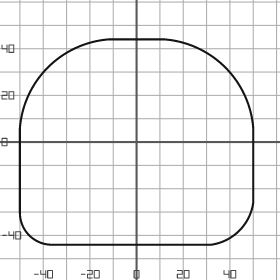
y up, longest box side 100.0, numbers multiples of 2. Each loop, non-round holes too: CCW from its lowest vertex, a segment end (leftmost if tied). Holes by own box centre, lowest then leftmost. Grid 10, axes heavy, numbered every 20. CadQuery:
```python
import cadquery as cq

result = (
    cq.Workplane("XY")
    .moveTo(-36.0, -44.0)
    .lineTo(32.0, -44.0)
    .threePointArc((44.0, -38.0), (50.0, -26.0))
    .lineTo(50.0, 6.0)
    .threePointArc((38.0, 32.0), (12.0, 44.0))
    .lineTo(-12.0, 44.0)
    .threePointArc((-38.0, 32.0), (-50.0, 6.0))
    .lineTo(-50.0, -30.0)
    .threePointArc((-46.0, -40.0), (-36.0, -44.0))
    .close()
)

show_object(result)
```